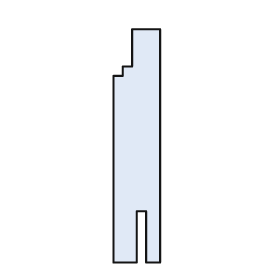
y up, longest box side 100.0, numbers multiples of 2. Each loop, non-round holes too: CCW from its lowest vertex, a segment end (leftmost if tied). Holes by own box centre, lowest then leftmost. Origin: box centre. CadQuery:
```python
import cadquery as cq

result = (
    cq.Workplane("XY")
    .moveTo(-10.0, -50.0)
    .lineTo(0.0, -50.0)
    .lineTo(0.0, -28.0)
    .lineTo(4.0, -28.0)
    .lineTo(4.0, -50.0)
    .lineTo(10.0, -50.0)
    .lineTo(10.0, 50.0)
    .lineTo(-2.0, 50.0)
    .lineTo(-2.0, 34.0)
    .lineTo(-6.0, 34.0)
    .lineTo(-6.0, 30.0)
    .lineTo(-10.0, 30.0)
    .close()
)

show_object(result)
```